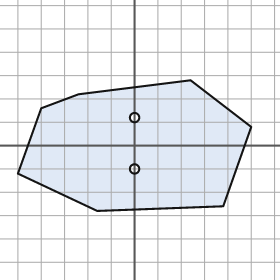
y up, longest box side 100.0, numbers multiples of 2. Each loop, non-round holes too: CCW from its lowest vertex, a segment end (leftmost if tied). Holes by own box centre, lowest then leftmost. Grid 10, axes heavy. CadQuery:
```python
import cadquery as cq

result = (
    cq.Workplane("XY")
    .moveTo(-16.0, -28.0)
    .lineTo(38.0, -26.0)
    .lineTo(50.0, 8.0)
    .lineTo(24.0, 28.0)
    .lineTo(-24.0, 22.0)
    .lineTo(-40.0, 16.0)
    .lineTo(-50.0, -12.0)
    .close()
    .moveTo(0.0, -10.0)
    .circle(2.0)
    .moveTo(0.0, 12.0)
    .circle(2.0)
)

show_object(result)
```